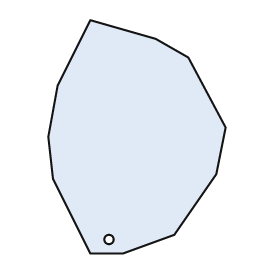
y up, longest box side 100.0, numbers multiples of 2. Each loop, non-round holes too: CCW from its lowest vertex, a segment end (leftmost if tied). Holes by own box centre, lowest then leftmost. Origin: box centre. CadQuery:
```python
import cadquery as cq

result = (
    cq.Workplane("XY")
    .moveTo(-20.0, -50.0)
    .lineTo(-6.0, -50.0)
    .lineTo(16.0, -42.0)
    .lineTo(34.0, -16.0)
    .lineTo(38.0, 4.0)
    .lineTo(22.0, 34.0)
    .lineTo(8.0, 42.0)
    .lineTo(-20.0, 50.0)
    .lineTo(-34.0, 22.0)
    .lineTo(-38.0, 0.0)
    .lineTo(-36.0, -18.0)
    .close()
    .moveTo(-12.0, -44.0)
    .circle(2.0)
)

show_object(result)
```